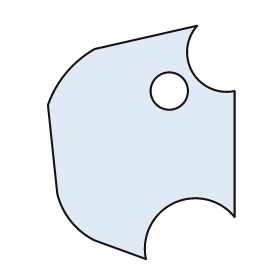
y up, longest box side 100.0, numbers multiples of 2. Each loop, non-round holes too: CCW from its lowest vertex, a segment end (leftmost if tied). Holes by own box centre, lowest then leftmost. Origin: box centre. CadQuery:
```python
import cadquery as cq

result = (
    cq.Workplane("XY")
    .moveTo(2.0, -50.0)
    .threePointArc((14.0, -26.0), (40.0, -32.0))
    .lineTo(40.0, 22.0)
    .threePointArc((22.0, 30.0), (24.0, 50.0))
    .lineTo(-20.0, 40.0)
    .threePointArc((-32.0, 30.0), (-40.0, 16.0))
    .lineTo(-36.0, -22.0)
    .threePointArc((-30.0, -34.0), (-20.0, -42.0))
    .close()
    .moveTo(12.0, 22.0)
    .circle(8.0)
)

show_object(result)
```